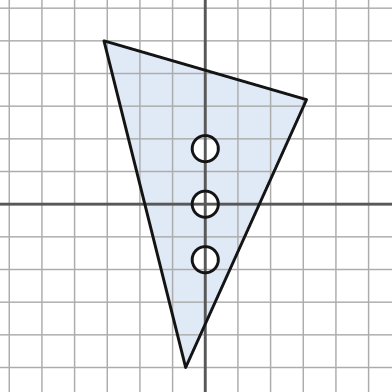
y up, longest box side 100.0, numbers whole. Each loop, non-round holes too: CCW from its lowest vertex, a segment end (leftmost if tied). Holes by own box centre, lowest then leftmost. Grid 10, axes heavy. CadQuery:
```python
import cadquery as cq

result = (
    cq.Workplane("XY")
    .moveTo(-6.0, -50.0)
    .lineTo(31.0, 32.0)
    .lineTo(-31.0, 50.0)
    .close()
    .moveTo(0.0, -17.0)
    .circle(4.0)
    .moveTo(0.0, 0.0)
    .circle(4.0)
    .moveTo(0.0, 17.0)
    .circle(4.0)
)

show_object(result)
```